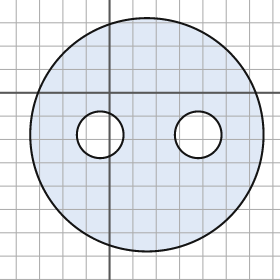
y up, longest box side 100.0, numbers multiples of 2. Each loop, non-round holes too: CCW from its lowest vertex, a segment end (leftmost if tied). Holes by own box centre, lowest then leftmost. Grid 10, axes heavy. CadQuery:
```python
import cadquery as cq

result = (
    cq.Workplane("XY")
    .moveTo(16.0, -18.0)
    .circle(50.0)
    .moveTo(-4.0, -18.0)
    .circle(10.0)
    .moveTo(38.0, -18.0)
    .circle(10.0)
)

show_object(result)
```